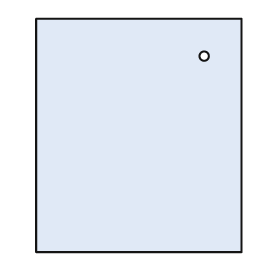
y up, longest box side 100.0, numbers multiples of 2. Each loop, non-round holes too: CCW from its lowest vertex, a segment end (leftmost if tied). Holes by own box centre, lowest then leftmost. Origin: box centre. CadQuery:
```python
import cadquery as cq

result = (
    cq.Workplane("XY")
    .moveTo(-44.0, -50.0)
    .lineTo(44.0, -50.0)
    .lineTo(44.0, 50.0)
    .lineTo(-44.0, 50.0)
    .close()
    .moveTo(28.0, 34.0)
    .circle(2.0)
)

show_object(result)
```